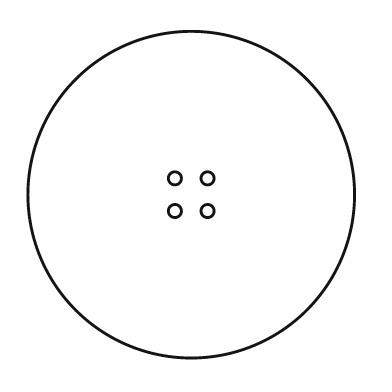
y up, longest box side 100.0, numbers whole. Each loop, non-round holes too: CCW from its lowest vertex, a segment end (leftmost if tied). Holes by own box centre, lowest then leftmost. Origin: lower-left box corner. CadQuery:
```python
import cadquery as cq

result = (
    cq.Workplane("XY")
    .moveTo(50.0, 50.0)
    .circle(50.0)
    .moveTo(45.0, 45.0)
    .circle(2.0)
    .moveTo(55.0, 45.0)
    .circle(2.0)
    .moveTo(45.0, 55.0)
    .circle(2.0)
    .moveTo(55.0, 55.0)
    .circle(2.0)
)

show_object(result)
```